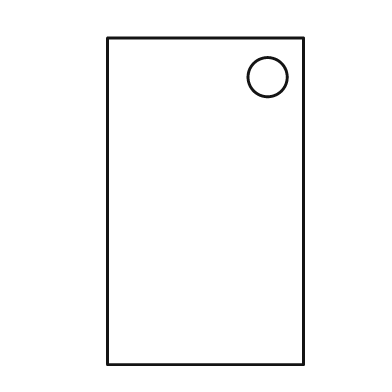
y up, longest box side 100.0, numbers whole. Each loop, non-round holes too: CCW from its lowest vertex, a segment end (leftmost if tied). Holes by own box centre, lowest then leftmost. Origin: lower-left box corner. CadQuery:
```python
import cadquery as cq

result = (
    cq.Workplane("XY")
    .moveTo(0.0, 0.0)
    .lineTo(60.0, 0.0)
    .lineTo(60.0, 100.0)
    .lineTo(0.0, 100.0)
    .close()
    .moveTo(49.0, 88.0)
    .circle(6.0)
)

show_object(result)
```